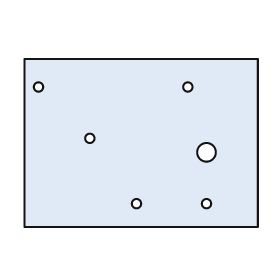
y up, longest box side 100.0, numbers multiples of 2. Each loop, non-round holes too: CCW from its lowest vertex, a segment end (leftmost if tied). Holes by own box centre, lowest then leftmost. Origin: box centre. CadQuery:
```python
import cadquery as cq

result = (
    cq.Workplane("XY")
    .moveTo(-50.0, -36.0)
    .lineTo(50.0, -36.0)
    .lineTo(50.0, 36.0)
    .lineTo(-50.0, 36.0)
    .close()
    .moveTo(-2.0, -26.0)
    .circle(2.0)
    .moveTo(28.0, -26.0)
    .circle(2.0)
    .moveTo(28.0, -4.0)
    .circle(4.0)
    .moveTo(-22.0, 2.0)
    .circle(2.0)
    .moveTo(-44.0, 24.0)
    .circle(2.0)
    .moveTo(20.0, 24.0)
    .circle(2.0)
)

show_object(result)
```